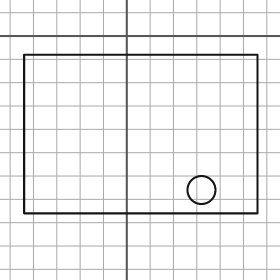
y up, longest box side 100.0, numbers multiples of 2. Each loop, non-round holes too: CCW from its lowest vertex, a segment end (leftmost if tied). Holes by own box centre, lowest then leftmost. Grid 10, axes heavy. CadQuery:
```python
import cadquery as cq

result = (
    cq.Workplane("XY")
    .moveTo(-44.0, -76.0)
    .lineTo(56.0, -76.0)
    .lineTo(56.0, -8.0)
    .lineTo(-44.0, -8.0)
    .close()
    .moveTo(32.0, -66.0)
    .circle(6.0)
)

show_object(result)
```